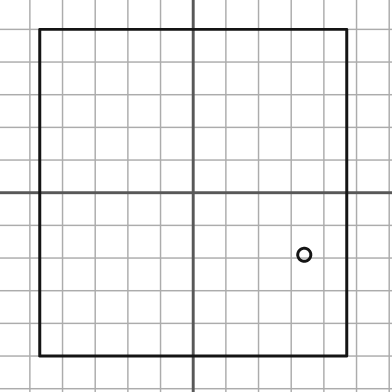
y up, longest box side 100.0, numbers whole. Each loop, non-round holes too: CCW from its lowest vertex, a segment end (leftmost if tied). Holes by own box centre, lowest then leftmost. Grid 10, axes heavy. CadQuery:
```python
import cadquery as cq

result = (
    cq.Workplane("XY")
    .moveTo(-47.0, -50.0)
    .lineTo(47.0, -50.0)
    .lineTo(47.0, 50.0)
    .lineTo(-47.0, 50.0)
    .close()
    .moveTo(34.0, -19.0)
    .circle(2.0)
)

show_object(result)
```